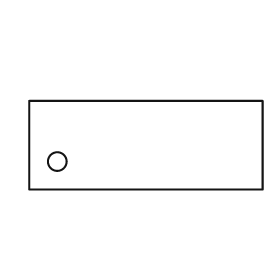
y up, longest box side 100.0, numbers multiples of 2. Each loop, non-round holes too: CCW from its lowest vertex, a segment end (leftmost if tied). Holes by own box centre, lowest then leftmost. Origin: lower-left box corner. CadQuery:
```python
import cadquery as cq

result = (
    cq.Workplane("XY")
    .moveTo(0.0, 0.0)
    .lineTo(100.0, 0.0)
    .lineTo(100.0, 38.0)
    .lineTo(0.0, 38.0)
    .close()
    .moveTo(12.0, 12.0)
    .circle(4.0)
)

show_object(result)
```